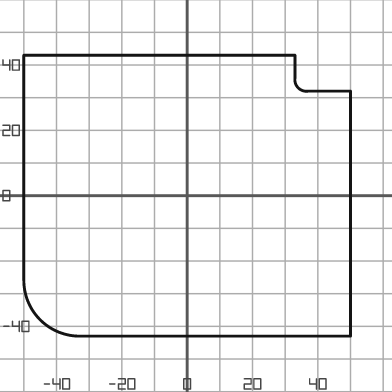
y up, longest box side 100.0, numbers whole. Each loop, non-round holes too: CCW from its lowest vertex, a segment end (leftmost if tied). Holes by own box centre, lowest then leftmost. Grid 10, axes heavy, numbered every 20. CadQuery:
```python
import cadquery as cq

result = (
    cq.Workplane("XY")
    .moveTo(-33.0, -43.0)
    .lineTo(50.0, -43.0)
    .lineTo(50.0, 32.0)
    .lineTo(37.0, 32.0)
    .threePointArc((34.0, 33.0), (33.0, 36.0))
    .lineTo(33.0, 43.0)
    .lineTo(-50.0, 43.0)
    .lineTo(-50.0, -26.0)
    .threePointArc((-45.0, -38.0), (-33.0, -43.0))
    .close()
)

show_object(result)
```